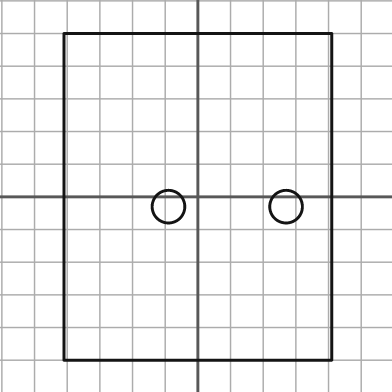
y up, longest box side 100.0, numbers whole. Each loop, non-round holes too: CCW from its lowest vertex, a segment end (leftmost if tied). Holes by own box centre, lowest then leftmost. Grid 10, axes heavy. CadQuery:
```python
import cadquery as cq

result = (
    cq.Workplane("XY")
    .moveTo(-41.0, -50.0)
    .lineTo(41.0, -50.0)
    .lineTo(41.0, 50.0)
    .lineTo(-41.0, 50.0)
    .close()
    .moveTo(-9.0, -3.0)
    .circle(5.0)
    .moveTo(27.0, -3.0)
    .circle(5.0)
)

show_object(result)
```